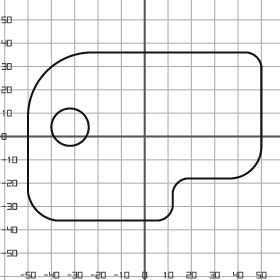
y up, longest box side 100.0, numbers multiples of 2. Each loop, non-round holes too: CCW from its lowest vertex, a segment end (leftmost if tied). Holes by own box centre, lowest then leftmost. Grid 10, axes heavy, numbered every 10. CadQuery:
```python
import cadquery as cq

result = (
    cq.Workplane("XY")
    .moveTo(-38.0, -36.0)
    .lineTo(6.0, -36.0)
    .threePointArc((10.0, -34.0), (12.0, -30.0))
    .lineTo(12.0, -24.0)
    .threePointArc((14.0, -20.0), (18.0, -18.0))
    .lineTo(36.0, -18.0)
    .threePointArc((46.0, -14.0), (50.0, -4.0))
    .lineTo(50.0, 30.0)
    .threePointArc((48.0, 34.0), (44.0, 36.0))
    .lineTo(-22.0, 36.0)
    .threePointArc((-42.0, 28.0), (-50.0, 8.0))
    .lineTo(-50.0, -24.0)
    .threePointArc((-46.0, -32.0), (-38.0, -36.0))
    .close()
    .moveTo(-32.0, 4.0)
    .circle(8.0)
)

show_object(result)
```